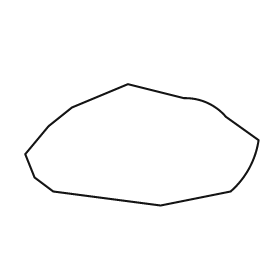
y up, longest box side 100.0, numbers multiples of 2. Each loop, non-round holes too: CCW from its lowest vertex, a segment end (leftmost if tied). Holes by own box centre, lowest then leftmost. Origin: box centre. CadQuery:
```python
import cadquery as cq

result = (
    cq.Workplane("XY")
    .moveTo(8.0, -26.0)
    .lineTo(38.0, -20.0)
    .threePointArc((46.0, -10.0), (50.0, 2.0))
    .lineTo(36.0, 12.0)
    .threePointArc((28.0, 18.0), (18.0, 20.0))
    .lineTo(-6.0, 26.0)
    .lineTo(-30.0, 16.0)
    .lineTo(-40.0, 8.0)
    .lineTo(-50.0, -4.0)
    .lineTo(-46.0, -14.0)
    .lineTo(-38.0, -20.0)
    .close()
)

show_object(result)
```